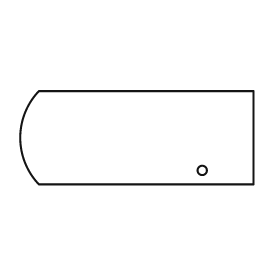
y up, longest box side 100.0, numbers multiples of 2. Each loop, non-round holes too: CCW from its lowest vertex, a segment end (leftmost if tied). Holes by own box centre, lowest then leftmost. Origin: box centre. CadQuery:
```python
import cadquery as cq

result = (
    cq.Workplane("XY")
    .moveTo(-42.0, -20.0)
    .lineTo(50.0, -20.0)
    .lineTo(50.0, 20.0)
    .lineTo(-42.0, 20.0)
    .threePointArc((-50.0, 0.0), (-42.0, -20.0))
    .close()
    .moveTo(28.0, -14.0)
    .circle(2.0)
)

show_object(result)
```